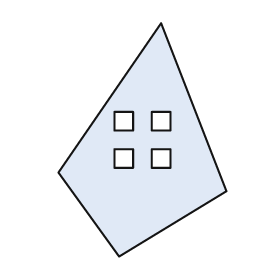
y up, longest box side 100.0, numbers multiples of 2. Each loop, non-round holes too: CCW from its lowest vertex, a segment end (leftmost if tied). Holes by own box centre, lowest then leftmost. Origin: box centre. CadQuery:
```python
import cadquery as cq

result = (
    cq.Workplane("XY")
    .moveTo(-10.0, -50.0)
    .lineTo(36.0, -22.0)
    .lineTo(8.0, 50.0)
    .lineTo(-36.0, -14.0)
    .close()
    .moveTo(-12.0, -12.0)
    .lineTo(-4.0, -12.0)
    .lineTo(-4.0, -4.0)
    .lineTo(-12.0, -4.0)
    .close()
    .moveTo(4.0, -12.0)
    .lineTo(12.0, -12.0)
    .lineTo(12.0, -4.0)
    .lineTo(4.0, -4.0)
    .close()
    .moveTo(-12.0, 4.0)
    .lineTo(-4.0, 4.0)
    .lineTo(-4.0, 12.0)
    .lineTo(-12.0, 12.0)
    .close()
    .moveTo(4.0, 4.0)
    .lineTo(12.0, 4.0)
    .lineTo(12.0, 12.0)
    .lineTo(4.0, 12.0)
    .close()
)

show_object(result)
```